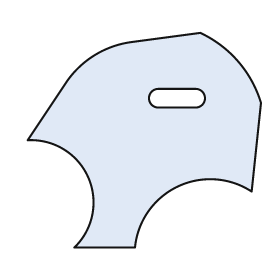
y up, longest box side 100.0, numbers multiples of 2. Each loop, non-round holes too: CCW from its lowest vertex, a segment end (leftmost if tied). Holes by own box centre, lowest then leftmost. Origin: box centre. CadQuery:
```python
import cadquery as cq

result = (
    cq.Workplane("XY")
    .moveTo(-30.0, -46.0)
    .lineTo(-4.0, -46.0)
    .threePointArc((14.0, -20.0), (46.0, -22.0))
    .lineTo(50.0, 16.0)
    .threePointArc((40.0, 34.0), (24.0, 46.0))
    .lineTo(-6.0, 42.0)
    .threePointArc((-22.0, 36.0), (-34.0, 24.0))
    .lineTo(-50.0, 0.0)
    .threePointArc((-24.0, -16.0), (-30.0, -46.0))
    .close()
    .moveTo(6.0, 14.0)
    .lineTo(22.0, 14.0)
    .threePointArc((26.0, 18.0), (22.0, 22.0))
    .lineTo(6.0, 22.0)
    .threePointArc((2.0, 18.0), (6.0, 14.0))
    .close()
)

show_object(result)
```